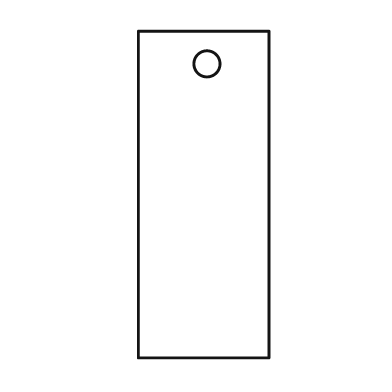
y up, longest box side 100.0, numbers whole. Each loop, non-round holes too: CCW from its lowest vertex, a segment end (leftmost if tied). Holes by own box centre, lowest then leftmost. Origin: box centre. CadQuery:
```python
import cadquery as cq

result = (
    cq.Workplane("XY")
    .moveTo(-20.0, -50.0)
    .lineTo(20.0, -50.0)
    .lineTo(20.0, 50.0)
    .lineTo(-20.0, 50.0)
    .close()
    .moveTo(1.0, 40.0)
    .circle(4.0)
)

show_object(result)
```